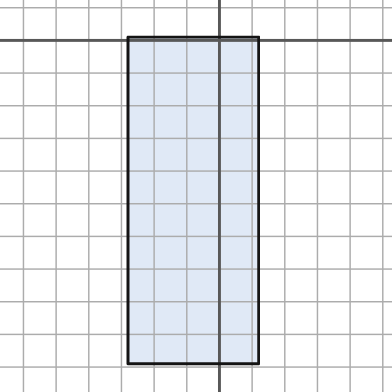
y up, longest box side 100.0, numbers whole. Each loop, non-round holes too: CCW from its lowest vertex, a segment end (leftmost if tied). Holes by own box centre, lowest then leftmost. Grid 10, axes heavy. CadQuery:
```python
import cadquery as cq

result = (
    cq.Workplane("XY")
    .moveTo(-28.0, -99.0)
    .lineTo(12.0, -99.0)
    .lineTo(12.0, 1.0)
    .lineTo(-28.0, 1.0)
    .close()
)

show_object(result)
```